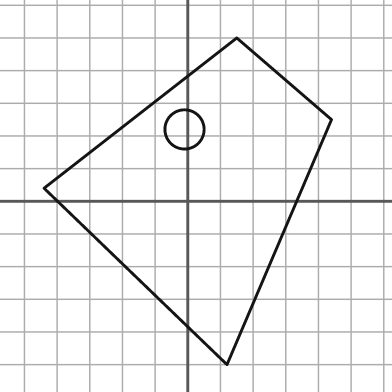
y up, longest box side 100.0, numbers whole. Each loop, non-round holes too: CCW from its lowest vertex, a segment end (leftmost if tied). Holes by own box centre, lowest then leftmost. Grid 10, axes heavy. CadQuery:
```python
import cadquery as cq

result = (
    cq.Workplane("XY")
    .moveTo(12.0, -50.0)
    .lineTo(44.0, 25.0)
    .lineTo(15.0, 50.0)
    .lineTo(-44.0, 4.0)
    .close()
    .moveTo(-1.0, 22.0)
    .circle(6.0)
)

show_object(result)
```